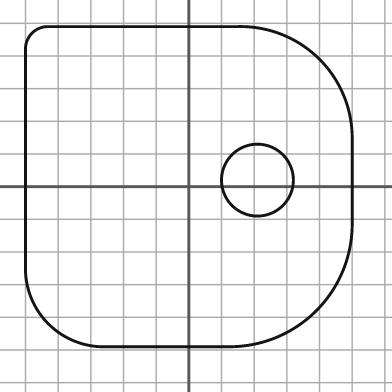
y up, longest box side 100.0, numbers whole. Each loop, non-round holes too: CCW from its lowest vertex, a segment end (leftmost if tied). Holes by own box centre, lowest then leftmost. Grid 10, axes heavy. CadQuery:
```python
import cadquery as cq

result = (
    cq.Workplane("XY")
    .moveTo(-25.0, -49.0)
    .lineTo(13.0, -49.0)
    .threePointArc((39.0, -38.0), (50.0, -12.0))
    .lineTo(50.0, 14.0)
    .threePointArc((40.0, 39.0), (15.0, 49.0))
    .lineTo(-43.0, 49.0)
    .threePointArc((-48.0, 47.0), (-50.0, 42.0))
    .lineTo(-50.0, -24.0)
    .threePointArc((-43.0, -42.0), (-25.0, -49.0))
    .close()
    .moveTo(21.0, 2.0)
    .circle(11.0)
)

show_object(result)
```